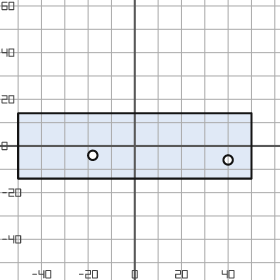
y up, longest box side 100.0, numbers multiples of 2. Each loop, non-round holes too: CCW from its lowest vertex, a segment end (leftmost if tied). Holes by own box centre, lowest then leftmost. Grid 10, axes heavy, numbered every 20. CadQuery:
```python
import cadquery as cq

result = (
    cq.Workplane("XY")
    .moveTo(-50.0, -14.0)
    .lineTo(50.0, -14.0)
    .lineTo(50.0, 14.0)
    .lineTo(-50.0, 14.0)
    .close()
    .moveTo(40.0, -6.0)
    .circle(2.0)
    .moveTo(-18.0, -4.0)
    .circle(2.0)
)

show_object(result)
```